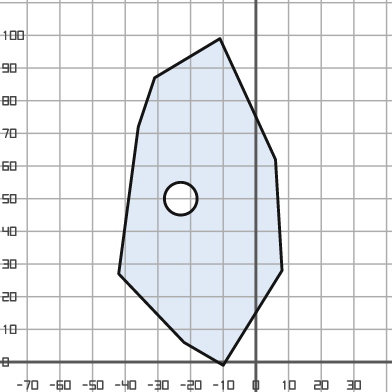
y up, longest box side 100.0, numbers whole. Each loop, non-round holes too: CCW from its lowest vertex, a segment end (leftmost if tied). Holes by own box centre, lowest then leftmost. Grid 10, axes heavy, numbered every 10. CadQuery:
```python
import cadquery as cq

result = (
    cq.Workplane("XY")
    .moveTo(-10.0, -1.0)
    .lineTo(8.0, 28.0)
    .lineTo(6.0, 62.0)
    .lineTo(-11.0, 99.0)
    .lineTo(-31.0, 87.0)
    .lineTo(-36.0, 72.0)
    .lineTo(-42.0, 27.0)
    .lineTo(-22.0, 6.0)
    .close()
    .moveTo(-23.0, 50.0)
    .circle(5.0)
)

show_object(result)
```